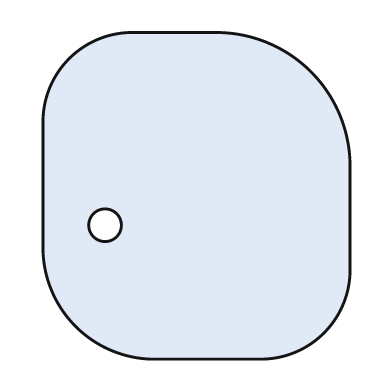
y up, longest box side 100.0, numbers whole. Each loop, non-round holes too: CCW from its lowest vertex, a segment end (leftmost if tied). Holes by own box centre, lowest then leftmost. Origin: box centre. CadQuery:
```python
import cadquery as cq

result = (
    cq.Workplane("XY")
    .moveTo(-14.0, -50.0)
    .lineTo(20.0, -50.0)
    .threePointArc((39.0, -42.0), (47.0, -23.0))
    .lineTo(47.0, 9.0)
    .threePointArc((35.0, 38.0), (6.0, 50.0))
    .lineTo(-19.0, 50.0)
    .threePointArc((-39.0, 42.0), (-47.0, 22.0))
    .lineTo(-47.0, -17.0)
    .threePointArc((-37.0, -40.0), (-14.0, -50.0))
    .close()
    .moveTo(-28.0, -9.0)
    .circle(5.0)
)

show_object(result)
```